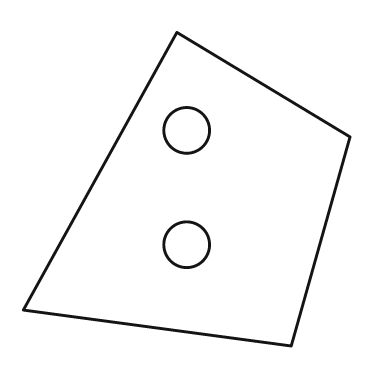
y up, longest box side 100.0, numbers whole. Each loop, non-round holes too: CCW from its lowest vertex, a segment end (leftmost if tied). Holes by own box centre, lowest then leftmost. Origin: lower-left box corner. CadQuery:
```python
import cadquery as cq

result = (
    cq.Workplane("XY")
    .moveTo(82.0, 0.0)
    .lineTo(100.0, 64.0)
    .lineTo(47.0, 96.0)
    .lineTo(0.0, 11.0)
    .close()
    .moveTo(50.0, 31.0)
    .circle(7.0)
    .moveTo(50.0, 66.0)
    .circle(7.0)
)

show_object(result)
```